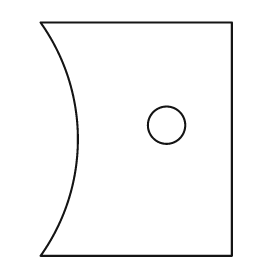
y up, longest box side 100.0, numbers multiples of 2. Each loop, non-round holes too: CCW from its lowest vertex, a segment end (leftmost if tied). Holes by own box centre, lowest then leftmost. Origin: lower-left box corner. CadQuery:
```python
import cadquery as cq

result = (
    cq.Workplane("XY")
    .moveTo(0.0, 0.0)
    .lineTo(82.0, 0.0)
    .lineTo(82.0, 100.0)
    .lineTo(0.0, 100.0)
    .threePointArc((16.0, 50.0), (0.0, 0.0))
    .close()
    .moveTo(54.0, 56.0)
    .circle(8.0)
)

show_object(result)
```